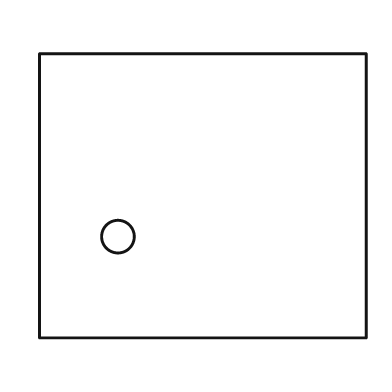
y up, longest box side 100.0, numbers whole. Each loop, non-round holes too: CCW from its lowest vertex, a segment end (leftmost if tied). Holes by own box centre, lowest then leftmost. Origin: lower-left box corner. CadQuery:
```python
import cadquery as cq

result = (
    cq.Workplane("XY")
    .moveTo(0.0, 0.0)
    .lineTo(100.0, 0.0)
    .lineTo(100.0, 87.0)
    .lineTo(0.0, 87.0)
    .close()
    .moveTo(24.0, 31.0)
    .circle(5.0)
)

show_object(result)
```